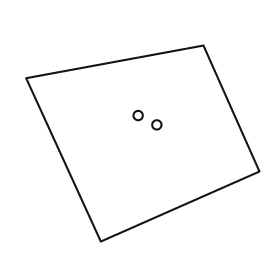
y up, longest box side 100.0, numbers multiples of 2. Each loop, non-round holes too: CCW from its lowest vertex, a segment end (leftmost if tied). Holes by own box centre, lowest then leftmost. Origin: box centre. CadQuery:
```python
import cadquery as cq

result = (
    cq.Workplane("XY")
    .moveTo(-18.0, -42.0)
    .lineTo(50.0, -12.0)
    .lineTo(26.0, 42.0)
    .lineTo(-50.0, 28.0)
    .close()
    .moveTo(6.0, 8.0)
    .circle(2.0)
    .moveTo(-2.0, 12.0)
    .circle(2.0)
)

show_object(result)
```